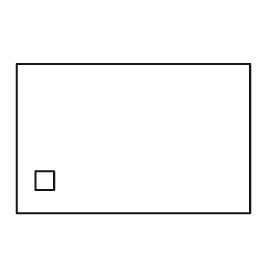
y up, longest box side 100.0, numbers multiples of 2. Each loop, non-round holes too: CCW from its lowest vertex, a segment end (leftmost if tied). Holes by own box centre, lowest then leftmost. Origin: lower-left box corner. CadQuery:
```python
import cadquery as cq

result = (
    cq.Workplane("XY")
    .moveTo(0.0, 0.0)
    .lineTo(100.0, 0.0)
    .lineTo(100.0, 64.0)
    .lineTo(0.0, 64.0)
    .close()
    .moveTo(8.0, 10.0)
    .lineTo(16.0, 10.0)
    .lineTo(16.0, 18.0)
    .lineTo(8.0, 18.0)
    .close()
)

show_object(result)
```